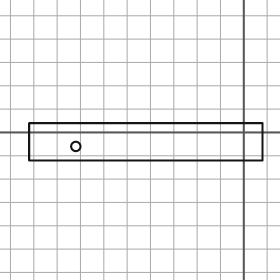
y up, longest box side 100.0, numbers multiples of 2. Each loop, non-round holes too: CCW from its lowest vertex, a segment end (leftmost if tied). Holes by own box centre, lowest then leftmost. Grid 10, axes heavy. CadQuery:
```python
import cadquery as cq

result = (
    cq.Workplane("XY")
    .moveTo(-92.0, -12.0)
    .lineTo(8.0, -12.0)
    .lineTo(8.0, 4.0)
    .lineTo(-92.0, 4.0)
    .close()
    .moveTo(-72.0, -6.0)
    .circle(2.0)
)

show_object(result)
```